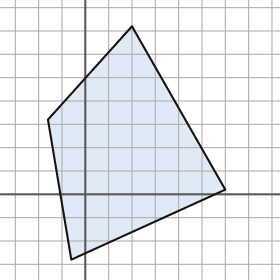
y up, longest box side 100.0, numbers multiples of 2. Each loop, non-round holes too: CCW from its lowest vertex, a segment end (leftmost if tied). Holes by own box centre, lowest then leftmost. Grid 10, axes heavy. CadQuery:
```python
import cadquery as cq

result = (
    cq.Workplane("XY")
    .moveTo(-6.0, -28.0)
    .lineTo(60.0, 2.0)
    .lineTo(20.0, 72.0)
    .lineTo(-16.0, 32.0)
    .close()
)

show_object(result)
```